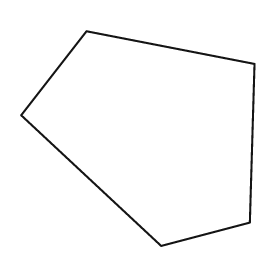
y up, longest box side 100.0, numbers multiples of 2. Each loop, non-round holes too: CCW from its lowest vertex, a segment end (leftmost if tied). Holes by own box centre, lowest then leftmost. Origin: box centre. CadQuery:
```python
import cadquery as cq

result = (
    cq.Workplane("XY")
    .moveTo(10.0, -46.0)
    .lineTo(48.0, -36.0)
    .lineTo(50.0, 32.0)
    .lineTo(-22.0, 46.0)
    .lineTo(-50.0, 10.0)
    .close()
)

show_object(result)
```